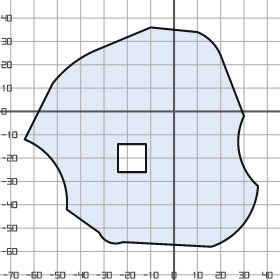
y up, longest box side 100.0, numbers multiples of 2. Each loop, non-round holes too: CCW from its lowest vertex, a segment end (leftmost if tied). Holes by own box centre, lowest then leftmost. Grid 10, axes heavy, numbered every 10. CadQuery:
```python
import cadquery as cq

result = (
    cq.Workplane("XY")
    .moveTo(16.0, -58.0)
    .threePointArc((30.0, -48.0), (36.0, -32.0))
    .threePointArc((28.0, -18.0), (30.0, -2.0))
    .lineTo(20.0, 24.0)
    .threePointArc((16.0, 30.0), (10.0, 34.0))
    .lineTo(-10.0, 36.0)
    .lineTo(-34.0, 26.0)
    .threePointArc((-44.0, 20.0), (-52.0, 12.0))
    .lineTo(-64.0, -12.0)
    .threePointArc((-50.0, -24.0), (-46.0, -42.0))
    .lineTo(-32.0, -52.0)
    .threePointArc((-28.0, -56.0), (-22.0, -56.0))
    .close()
    .moveTo(-24.0, -26.0)
    .lineTo(-12.0, -26.0)
    .lineTo(-12.0, -14.0)
    .lineTo(-24.0, -14.0)
    .close()
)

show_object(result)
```